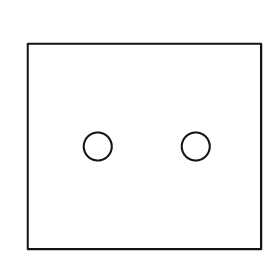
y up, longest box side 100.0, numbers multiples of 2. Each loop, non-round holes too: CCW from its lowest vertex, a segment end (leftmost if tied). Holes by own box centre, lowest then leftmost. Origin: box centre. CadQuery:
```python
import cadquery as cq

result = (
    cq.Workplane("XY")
    .moveTo(-50.0, -44.0)
    .lineTo(50.0, -44.0)
    .lineTo(50.0, 44.0)
    .lineTo(-50.0, 44.0)
    .close()
    .moveTo(-20.0, 0.0)
    .circle(6.0)
    .moveTo(22.0, 0.0)
    .circle(6.0)
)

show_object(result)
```